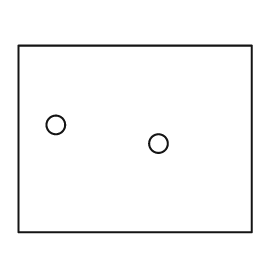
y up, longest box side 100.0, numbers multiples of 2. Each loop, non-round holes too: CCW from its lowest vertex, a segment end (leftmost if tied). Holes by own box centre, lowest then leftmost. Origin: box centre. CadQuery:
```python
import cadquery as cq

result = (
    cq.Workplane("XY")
    .moveTo(-50.0, -40.0)
    .lineTo(50.0, -40.0)
    .lineTo(50.0, 40.0)
    .lineTo(-50.0, 40.0)
    .close()
    .moveTo(10.0, -2.0)
    .circle(4.0)
    .moveTo(-34.0, 6.0)
    .circle(4.0)
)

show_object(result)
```